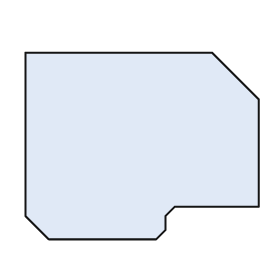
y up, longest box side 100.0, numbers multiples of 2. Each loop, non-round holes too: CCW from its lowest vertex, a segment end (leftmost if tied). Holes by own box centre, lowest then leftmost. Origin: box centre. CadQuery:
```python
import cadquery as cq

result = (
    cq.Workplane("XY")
    .moveTo(-40.0, -40.0)
    .lineTo(6.0, -40.0)
    .lineTo(10.0, -36.0)
    .lineTo(10.0, -30.0)
    .lineTo(14.0, -26.0)
    .lineTo(50.0, -26.0)
    .lineTo(50.0, 20.0)
    .lineTo(30.0, 40.0)
    .lineTo(-50.0, 40.0)
    .lineTo(-50.0, -30.0)
    .close()
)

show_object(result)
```